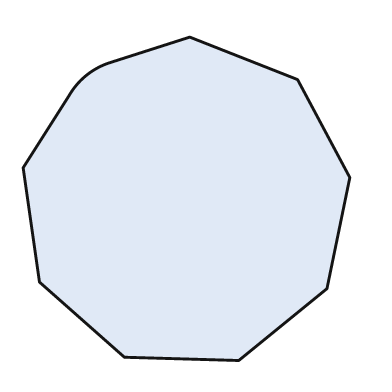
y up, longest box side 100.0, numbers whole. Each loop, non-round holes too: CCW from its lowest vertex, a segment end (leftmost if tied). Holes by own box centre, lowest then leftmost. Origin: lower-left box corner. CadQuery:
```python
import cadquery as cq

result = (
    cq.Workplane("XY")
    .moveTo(66.0, 0.0)
    .lineTo(93.0, 22.0)
    .lineTo(100.0, 56.0)
    .lineTo(84.0, 86.0)
    .lineTo(51.0, 99.0)
    .lineTo(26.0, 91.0)
    .threePointArc((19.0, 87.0), (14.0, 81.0))
    .lineTo(0.0, 59.0)
    .lineTo(5.0, 24.0)
    .lineTo(31.0, 1.0)
    .close()
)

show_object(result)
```